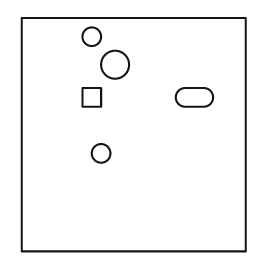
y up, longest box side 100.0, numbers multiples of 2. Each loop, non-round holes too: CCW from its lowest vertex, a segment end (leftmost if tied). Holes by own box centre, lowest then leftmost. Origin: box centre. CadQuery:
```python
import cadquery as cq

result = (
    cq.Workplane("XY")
    .moveTo(-48.0, -50.0)
    .lineTo(48.0, -50.0)
    .lineTo(48.0, 50.0)
    .lineTo(-48.0, 50.0)
    .close()
    .moveTo(-14.0, -8.0)
    .circle(4.0)
    .moveTo(-22.0, 12.0)
    .lineTo(-14.0, 12.0)
    .lineTo(-14.0, 20.0)
    .lineTo(-22.0, 20.0)
    .close()
    .moveTo(22.0, 12.0)
    .lineTo(30.0, 12.0)
    .threePointArc((34.0, 16.0), (30.0, 20.0))
    .lineTo(22.0, 20.0)
    .threePointArc((18.0, 16.0), (22.0, 12.0))
    .close()
    .moveTo(-8.0, 30.0)
    .circle(6.0)
    .moveTo(-18.0, 42.0)
    .circle(4.0)
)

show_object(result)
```